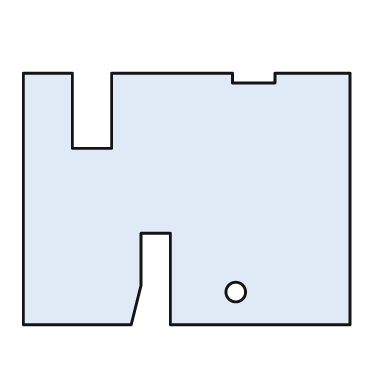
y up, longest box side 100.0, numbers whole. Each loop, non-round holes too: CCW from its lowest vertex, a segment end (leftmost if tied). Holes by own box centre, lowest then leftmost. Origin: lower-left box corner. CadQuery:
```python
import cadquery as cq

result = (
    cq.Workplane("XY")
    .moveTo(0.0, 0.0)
    .lineTo(33.0, 0.0)
    .lineTo(36.0, 12.0)
    .lineTo(36.0, 28.0)
    .lineTo(45.0, 28.0)
    .lineTo(45.0, 0.0)
    .lineTo(100.0, 0.0)
    .lineTo(100.0, 77.0)
    .lineTo(77.0, 77.0)
    .lineTo(77.0, 74.0)
    .lineTo(64.0, 74.0)
    .lineTo(64.0, 77.0)
    .lineTo(27.0, 77.0)
    .lineTo(27.0, 54.0)
    .lineTo(15.0, 54.0)
    .lineTo(15.0, 77.0)
    .lineTo(0.0, 77.0)
    .close()
    .moveTo(65.0, 10.0)
    .circle(3.0)
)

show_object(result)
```